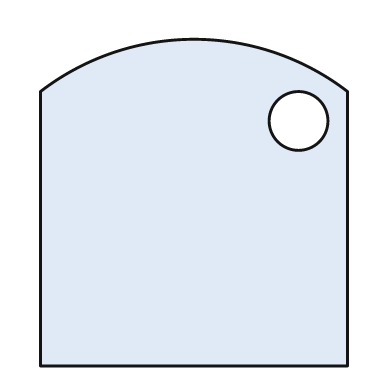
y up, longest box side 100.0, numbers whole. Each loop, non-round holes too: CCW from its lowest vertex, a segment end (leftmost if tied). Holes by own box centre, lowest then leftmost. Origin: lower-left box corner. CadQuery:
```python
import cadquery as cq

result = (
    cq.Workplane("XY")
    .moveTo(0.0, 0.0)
    .lineTo(94.0, 0.0)
    .lineTo(94.0, 84.0)
    .threePointArc((47.0, 100.0), (0.0, 84.0))
    .close()
    .moveTo(79.0, 75.0)
    .circle(9.0)
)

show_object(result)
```